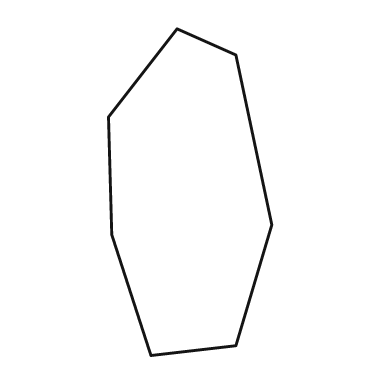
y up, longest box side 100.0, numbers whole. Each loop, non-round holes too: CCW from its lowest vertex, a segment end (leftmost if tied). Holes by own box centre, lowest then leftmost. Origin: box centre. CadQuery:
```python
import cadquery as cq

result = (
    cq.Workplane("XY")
    .moveTo(-12.0, -50.0)
    .lineTo(14.0, -47.0)
    .lineTo(25.0, -10.0)
    .lineTo(14.0, 42.0)
    .lineTo(-4.0, 50.0)
    .lineTo(-25.0, 23.0)
    .lineTo(-24.0, -13.0)
    .close()
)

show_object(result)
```